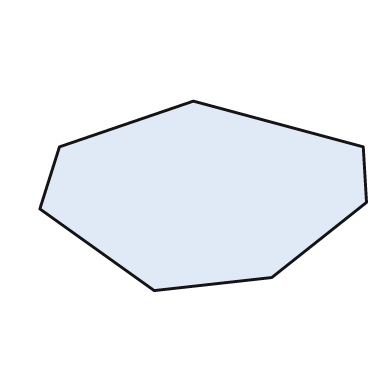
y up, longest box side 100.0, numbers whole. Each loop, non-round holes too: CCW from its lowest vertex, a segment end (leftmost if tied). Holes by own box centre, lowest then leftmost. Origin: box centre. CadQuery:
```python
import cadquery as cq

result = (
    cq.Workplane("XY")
    .moveTo(-15.0, -29.0)
    .lineTo(21.0, -25.0)
    .lineTo(50.0, -2.0)
    .lineTo(49.0, 15.0)
    .lineTo(-3.0, 29.0)
    .lineTo(-44.0, 15.0)
    .lineTo(-50.0, -4.0)
    .close()
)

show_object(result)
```